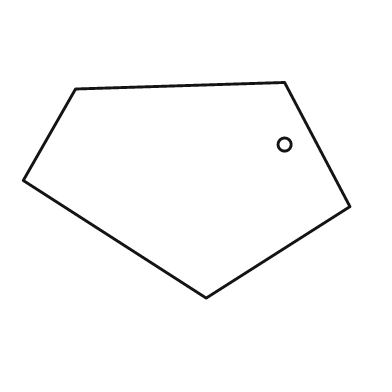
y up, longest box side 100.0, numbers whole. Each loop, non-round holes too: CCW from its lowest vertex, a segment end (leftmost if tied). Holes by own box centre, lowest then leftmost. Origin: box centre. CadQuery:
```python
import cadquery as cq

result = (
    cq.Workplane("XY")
    .moveTo(6.0, -33.0)
    .lineTo(50.0, -5.0)
    .lineTo(30.0, 33.0)
    .lineTo(-34.0, 31.0)
    .lineTo(-50.0, 3.0)
    .close()
    .moveTo(30.0, 14.0)
    .circle(2.0)
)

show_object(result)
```